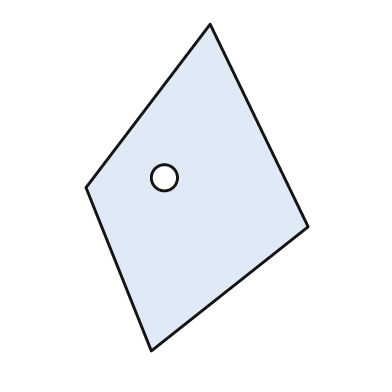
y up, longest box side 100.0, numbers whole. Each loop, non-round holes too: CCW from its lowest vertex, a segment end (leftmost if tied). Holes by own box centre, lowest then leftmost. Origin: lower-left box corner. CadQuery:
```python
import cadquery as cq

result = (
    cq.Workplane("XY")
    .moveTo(20.0, 0.0)
    .lineTo(68.0, 38.0)
    .lineTo(38.0, 100.0)
    .lineTo(0.0, 50.0)
    .close()
    .moveTo(24.0, 53.0)
    .circle(4.0)
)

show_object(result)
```